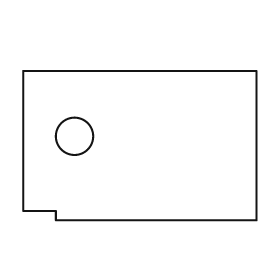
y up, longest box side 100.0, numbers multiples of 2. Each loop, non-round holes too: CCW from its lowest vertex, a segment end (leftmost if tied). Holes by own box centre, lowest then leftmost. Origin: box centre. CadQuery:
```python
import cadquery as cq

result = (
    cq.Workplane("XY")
    .moveTo(-36.0, -32.0)
    .lineTo(50.0, -32.0)
    .lineTo(50.0, 32.0)
    .lineTo(-50.0, 32.0)
    .lineTo(-50.0, -28.0)
    .lineTo(-36.0, -28.0)
    .close()
    .moveTo(-28.0, 4.0)
    .circle(8.0)
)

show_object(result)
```